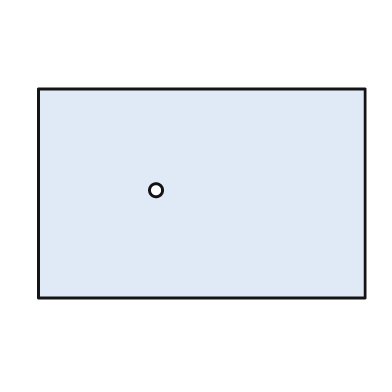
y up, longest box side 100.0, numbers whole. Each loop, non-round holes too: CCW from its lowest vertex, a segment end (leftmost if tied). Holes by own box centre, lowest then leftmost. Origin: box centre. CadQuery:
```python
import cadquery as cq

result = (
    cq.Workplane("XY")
    .moveTo(-50.0, -32.0)
    .lineTo(50.0, -32.0)
    .lineTo(50.0, 32.0)
    .lineTo(-50.0, 32.0)
    .close()
    .moveTo(-14.0, 1.0)
    .circle(2.0)
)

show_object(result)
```